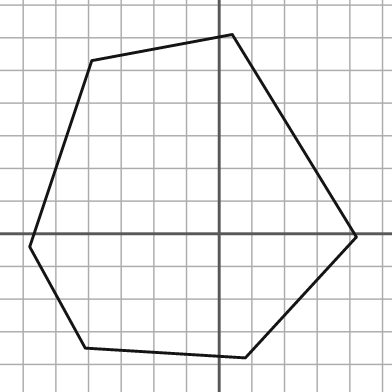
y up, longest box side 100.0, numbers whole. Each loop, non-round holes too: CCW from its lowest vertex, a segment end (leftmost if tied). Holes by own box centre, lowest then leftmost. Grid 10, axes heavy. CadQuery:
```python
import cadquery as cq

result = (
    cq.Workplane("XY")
    .moveTo(8.0, -38.0)
    .lineTo(42.0, -1.0)
    .lineTo(4.0, 61.0)
    .lineTo(-39.0, 53.0)
    .lineTo(-58.0, -4.0)
    .lineTo(-41.0, -35.0)
    .close()
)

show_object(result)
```